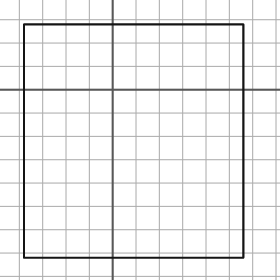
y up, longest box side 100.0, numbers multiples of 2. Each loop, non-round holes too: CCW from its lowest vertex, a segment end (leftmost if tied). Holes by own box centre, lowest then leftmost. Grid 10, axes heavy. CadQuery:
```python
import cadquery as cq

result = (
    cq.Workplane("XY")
    .moveTo(-38.0, -72.0)
    .lineTo(56.0, -72.0)
    .lineTo(56.0, 28.0)
    .lineTo(-38.0, 28.0)
    .close()
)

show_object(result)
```